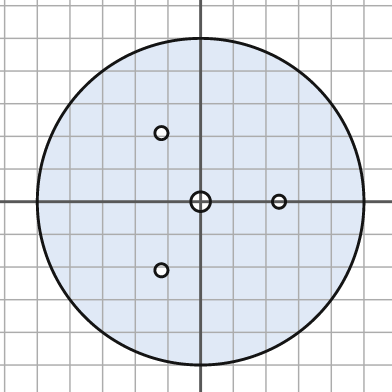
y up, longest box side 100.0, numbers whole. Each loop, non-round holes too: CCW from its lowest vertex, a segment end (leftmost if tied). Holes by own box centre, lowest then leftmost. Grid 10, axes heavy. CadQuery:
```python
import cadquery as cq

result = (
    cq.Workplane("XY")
    .moveTo(0.0, 0.0)
    .circle(50.0)
    .moveTo(-12.0, -21.0)
    .circle(2.0)
    .moveTo(0.0, 0.0)
    .circle(3.0)
    .moveTo(24.0, 0.0)
    .circle(2.0)
    .moveTo(-12.0, 21.0)
    .circle(2.0)
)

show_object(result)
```